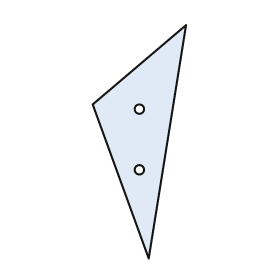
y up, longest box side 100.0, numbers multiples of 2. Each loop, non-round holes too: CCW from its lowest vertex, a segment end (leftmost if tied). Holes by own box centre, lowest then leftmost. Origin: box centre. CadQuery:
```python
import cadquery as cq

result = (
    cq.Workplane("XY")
    .moveTo(4.0, -50.0)
    .lineTo(20.0, 50.0)
    .lineTo(-20.0, 16.0)
    .close()
    .moveTo(0.0, -12.0)
    .circle(2.0)
    .moveTo(0.0, 14.0)
    .circle(2.0)
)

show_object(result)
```